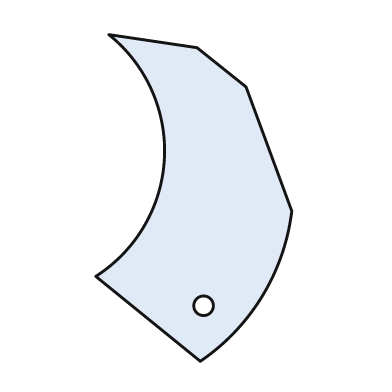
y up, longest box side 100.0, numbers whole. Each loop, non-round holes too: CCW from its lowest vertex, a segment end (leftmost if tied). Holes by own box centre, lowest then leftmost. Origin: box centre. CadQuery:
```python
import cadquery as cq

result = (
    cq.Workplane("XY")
    .moveTo(2.0, -50.0)
    .threePointArc((21.0, -30.0), (30.0, -4.0))
    .lineTo(16.0, 34.0)
    .lineTo(1.0, 46.0)
    .lineTo(-26.0, 50.0)
    .threePointArc((-9.0, 12.0), (-30.0, -24.0))
    .close()
    .moveTo(3.0, -33.0)
    .circle(3.0)
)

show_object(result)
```